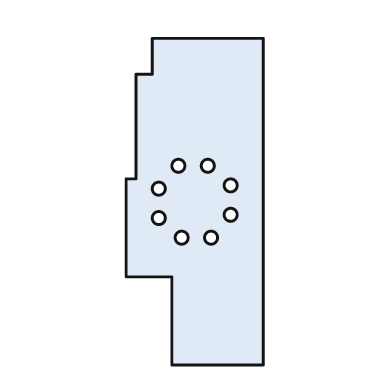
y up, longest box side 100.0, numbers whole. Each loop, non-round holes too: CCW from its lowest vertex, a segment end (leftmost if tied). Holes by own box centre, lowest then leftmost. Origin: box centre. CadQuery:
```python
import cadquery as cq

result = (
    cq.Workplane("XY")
    .moveTo(-7.0, -50.0)
    .lineTo(21.0, -50.0)
    .lineTo(21.0, 50.0)
    .lineTo(-13.0, 50.0)
    .lineTo(-13.0, 39.0)
    .lineTo(-18.0, 39.0)
    .lineTo(-18.0, 7.0)
    .lineTo(-21.0, 7.0)
    .lineTo(-21.0, -23.0)
    .lineTo(-7.0, -23.0)
    .close()
    .moveTo(-4.0, -11.0)
    .circle(2.0)
    .moveTo(5.0, -11.0)
    .circle(2.0)
    .moveTo(-11.0, -5.0)
    .circle(2.0)
    .moveTo(11.0, -4.0)
    .circle(2.0)
    .moveTo(-11.0, 4.0)
    .circle(2.0)
    .moveTo(11.0, 5.0)
    .circle(2.0)
    .moveTo(-5.0, 11.0)
    .circle(2.0)
    .moveTo(4.0, 11.0)
    .circle(2.0)
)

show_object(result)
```